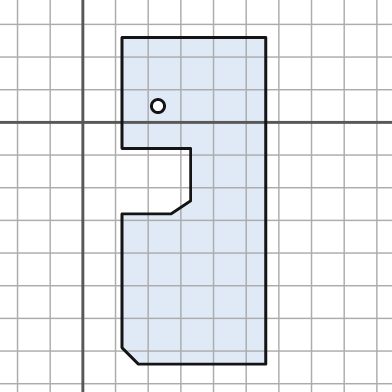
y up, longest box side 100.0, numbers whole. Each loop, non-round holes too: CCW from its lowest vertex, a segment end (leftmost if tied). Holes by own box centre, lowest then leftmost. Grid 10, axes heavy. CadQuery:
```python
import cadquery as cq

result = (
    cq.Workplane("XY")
    .moveTo(17.0, -74.0)
    .lineTo(56.0, -74.0)
    .lineTo(56.0, 26.0)
    .lineTo(12.0, 26.0)
    .lineTo(12.0, -8.0)
    .lineTo(33.0, -8.0)
    .lineTo(33.0, -24.0)
    .lineTo(27.0, -28.0)
    .lineTo(12.0, -28.0)
    .lineTo(12.0, -69.0)
    .close()
    .moveTo(23.0, 5.0)
    .circle(2.0)
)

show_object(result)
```